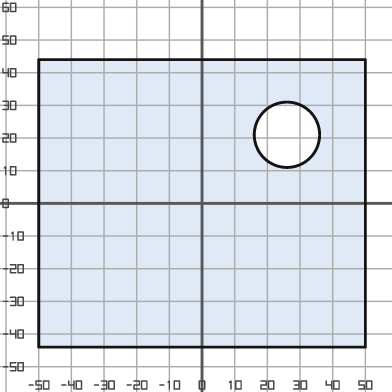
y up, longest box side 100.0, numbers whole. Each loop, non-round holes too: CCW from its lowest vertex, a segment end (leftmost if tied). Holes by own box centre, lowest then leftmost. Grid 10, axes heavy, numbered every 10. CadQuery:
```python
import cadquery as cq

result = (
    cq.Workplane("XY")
    .moveTo(-50.0, -44.0)
    .lineTo(50.0, -44.0)
    .lineTo(50.0, 44.0)
    .lineTo(-50.0, 44.0)
    .close()
    .moveTo(26.0, 21.0)
    .circle(10.0)
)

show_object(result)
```